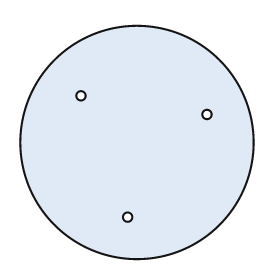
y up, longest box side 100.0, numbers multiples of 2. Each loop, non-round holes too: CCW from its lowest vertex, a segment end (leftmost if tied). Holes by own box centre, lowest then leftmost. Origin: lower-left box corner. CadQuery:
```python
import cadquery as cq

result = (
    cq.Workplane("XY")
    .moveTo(50.0, 50.0)
    .circle(50.0)
    .moveTo(46.0, 18.0)
    .circle(2.0)
    .moveTo(80.0, 62.0)
    .circle(2.0)
    .moveTo(26.0, 70.0)
    .circle(2.0)
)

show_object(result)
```